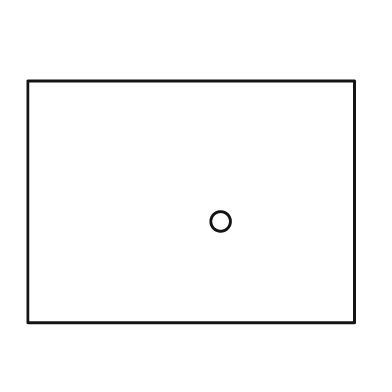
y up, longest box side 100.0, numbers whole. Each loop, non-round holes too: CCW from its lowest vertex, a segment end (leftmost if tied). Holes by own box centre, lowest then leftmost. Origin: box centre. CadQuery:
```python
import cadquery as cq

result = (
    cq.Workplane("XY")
    .moveTo(-50.0, -37.0)
    .lineTo(50.0, -37.0)
    .lineTo(50.0, 37.0)
    .lineTo(-50.0, 37.0)
    .close()
    .moveTo(9.0, -6.0)
    .circle(3.0)
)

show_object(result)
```